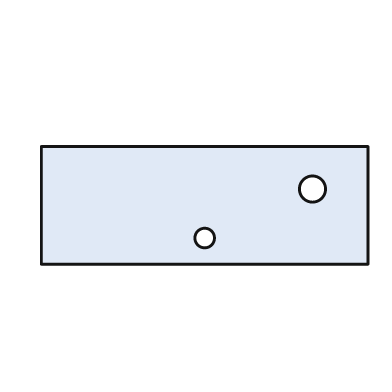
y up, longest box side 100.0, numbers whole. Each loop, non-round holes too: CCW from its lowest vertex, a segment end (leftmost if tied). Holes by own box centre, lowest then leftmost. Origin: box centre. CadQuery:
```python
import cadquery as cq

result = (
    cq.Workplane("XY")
    .moveTo(-50.0, -18.0)
    .lineTo(50.0, -18.0)
    .lineTo(50.0, 18.0)
    .lineTo(-50.0, 18.0)
    .close()
    .moveTo(0.0, -10.0)
    .circle(3.0)
    .moveTo(33.0, 5.0)
    .circle(4.0)
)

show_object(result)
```